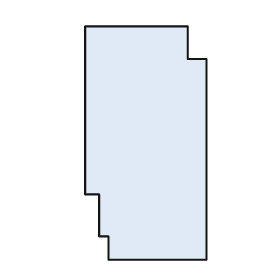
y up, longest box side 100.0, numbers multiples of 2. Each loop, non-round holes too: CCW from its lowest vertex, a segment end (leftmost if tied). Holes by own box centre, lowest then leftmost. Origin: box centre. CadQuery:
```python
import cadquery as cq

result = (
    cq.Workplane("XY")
    .moveTo(-16.0, -50.0)
    .lineTo(26.0, -50.0)
    .lineTo(26.0, 36.0)
    .lineTo(18.0, 36.0)
    .lineTo(18.0, 50.0)
    .lineTo(-26.0, 50.0)
    .lineTo(-26.0, -22.0)
    .lineTo(-20.0, -22.0)
    .lineTo(-20.0, -40.0)
    .lineTo(-16.0, -40.0)
    .close()
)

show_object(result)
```